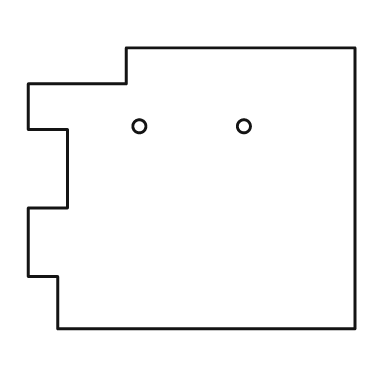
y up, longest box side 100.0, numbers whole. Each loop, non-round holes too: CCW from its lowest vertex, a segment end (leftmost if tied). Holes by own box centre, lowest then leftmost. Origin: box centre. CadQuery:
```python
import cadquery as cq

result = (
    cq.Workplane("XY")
    .moveTo(-41.0, -43.0)
    .lineTo(50.0, -43.0)
    .lineTo(50.0, 43.0)
    .lineTo(-20.0, 43.0)
    .lineTo(-20.0, 32.0)
    .lineTo(-50.0, 32.0)
    .lineTo(-50.0, 18.0)
    .lineTo(-38.0, 18.0)
    .lineTo(-38.0, -6.0)
    .lineTo(-50.0, -6.0)
    .lineTo(-50.0, -27.0)
    .lineTo(-41.0, -27.0)
    .close()
    .moveTo(-16.0, 19.0)
    .circle(2.0)
    .moveTo(16.0, 19.0)
    .circle(2.0)
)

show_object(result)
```